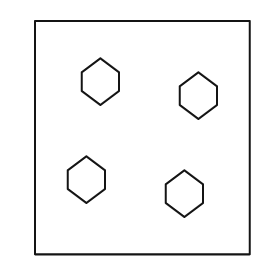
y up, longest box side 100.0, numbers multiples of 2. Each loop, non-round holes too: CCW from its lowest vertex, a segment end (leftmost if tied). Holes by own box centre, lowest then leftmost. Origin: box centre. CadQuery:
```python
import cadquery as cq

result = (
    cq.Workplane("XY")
    .moveTo(-46.0, -50.0)
    .lineTo(46.0, -50.0)
    .lineTo(46.0, 50.0)
    .lineTo(-46.0, 50.0)
    .close()
    .moveTo(18.0, -34.0)
    .lineTo(26.0, -28.0)
    .lineTo(26.0, -20.0)
    .lineTo(18.0, -14.0)
    .lineTo(10.0, -20.0)
    .lineTo(10.0, -28.0)
    .close()
    .moveTo(-24.0, -28.0)
    .lineTo(-16.0, -22.0)
    .lineTo(-16.0, -14.0)
    .lineTo(-24.0, -8.0)
    .lineTo(-32.0, -14.0)
    .lineTo(-32.0, -22.0)
    .close()
    .moveTo(24.0, 8.0)
    .lineTo(32.0, 14.0)
    .lineTo(32.0, 22.0)
    .lineTo(24.0, 28.0)
    .lineTo(16.0, 22.0)
    .lineTo(16.0, 14.0)
    .close()
    .moveTo(-18.0, 14.0)
    .lineTo(-10.0, 20.0)
    .lineTo(-10.0, 28.0)
    .lineTo(-18.0, 34.0)
    .lineTo(-26.0, 28.0)
    .lineTo(-26.0, 20.0)
    .close()
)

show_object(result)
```